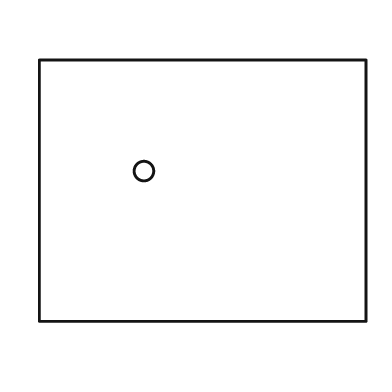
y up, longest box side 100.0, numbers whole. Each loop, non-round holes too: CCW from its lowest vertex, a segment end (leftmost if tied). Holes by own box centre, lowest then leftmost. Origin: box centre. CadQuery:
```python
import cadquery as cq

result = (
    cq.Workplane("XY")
    .moveTo(-50.0, -40.0)
    .lineTo(50.0, -40.0)
    .lineTo(50.0, 40.0)
    .lineTo(-50.0, 40.0)
    .close()
    .moveTo(-18.0, 6.0)
    .circle(3.0)
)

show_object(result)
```